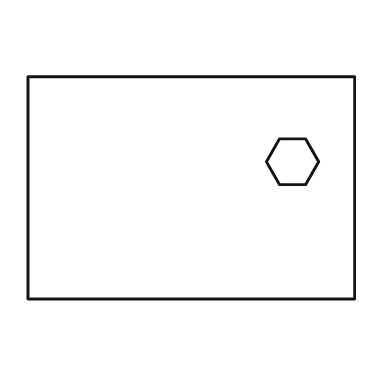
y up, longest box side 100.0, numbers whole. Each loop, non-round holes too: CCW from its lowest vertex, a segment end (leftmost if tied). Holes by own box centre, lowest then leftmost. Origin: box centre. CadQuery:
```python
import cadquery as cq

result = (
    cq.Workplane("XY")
    .moveTo(-50.0, -34.0)
    .lineTo(50.0, -34.0)
    .lineTo(50.0, 34.0)
    .lineTo(-50.0, 34.0)
    .close()
    .moveTo(27.0, 1.0)
    .lineTo(35.0, 1.0)
    .lineTo(39.0, 8.0)
    .lineTo(35.0, 15.0)
    .lineTo(27.0, 15.0)
    .lineTo(23.0, 8.0)
    .close()
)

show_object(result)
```